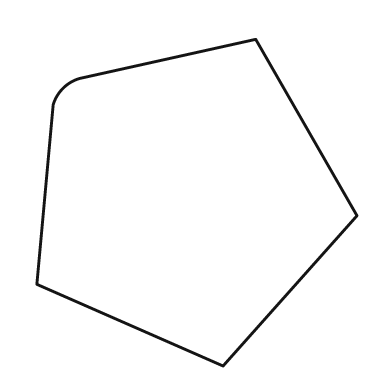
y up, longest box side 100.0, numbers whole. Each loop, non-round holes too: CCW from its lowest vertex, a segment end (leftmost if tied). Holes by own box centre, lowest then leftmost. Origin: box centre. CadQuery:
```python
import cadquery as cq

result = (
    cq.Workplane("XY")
    .moveTo(8.0, -50.0)
    .lineTo(49.0, -4.0)
    .lineTo(18.0, 50.0)
    .lineTo(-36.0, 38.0)
    .threePointArc((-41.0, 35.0), (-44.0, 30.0))
    .lineTo(-49.0, -25.0)
    .close()
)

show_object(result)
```